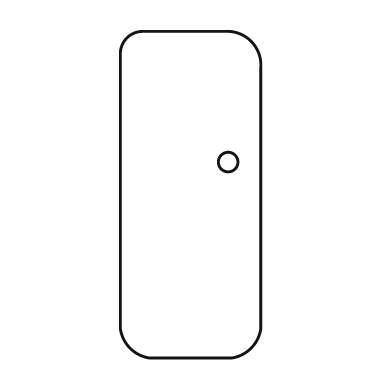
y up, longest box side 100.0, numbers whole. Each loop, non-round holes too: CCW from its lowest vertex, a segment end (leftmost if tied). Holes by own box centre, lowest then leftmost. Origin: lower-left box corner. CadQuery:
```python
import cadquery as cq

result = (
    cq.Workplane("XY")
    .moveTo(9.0, 0.0)
    .lineTo(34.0, 0.0)
    .threePointArc((40.0, 3.0), (43.0, 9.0))
    .lineTo(43.0, 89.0)
    .threePointArc((40.0, 97.0), (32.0, 100.0))
    .lineTo(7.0, 100.0)
    .threePointArc((2.0, 98.0), (0.0, 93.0))
    .lineTo(0.0, 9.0)
    .threePointArc((3.0, 3.0), (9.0, 0.0))
    .close()
    .moveTo(33.0, 60.0)
    .circle(3.0)
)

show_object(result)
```